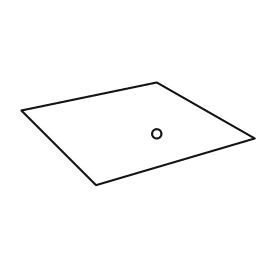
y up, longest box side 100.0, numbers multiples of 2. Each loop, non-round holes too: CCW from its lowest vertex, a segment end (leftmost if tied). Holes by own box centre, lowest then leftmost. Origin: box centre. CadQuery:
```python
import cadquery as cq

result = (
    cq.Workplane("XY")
    .moveTo(-18.0, -22.0)
    .lineTo(50.0, -2.0)
    .lineTo(8.0, 22.0)
    .lineTo(-50.0, 10.0)
    .close()
    .moveTo(8.0, 0.0)
    .circle(2.0)
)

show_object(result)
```